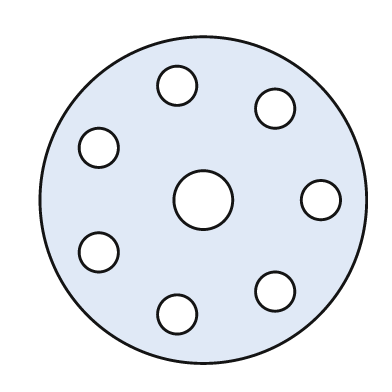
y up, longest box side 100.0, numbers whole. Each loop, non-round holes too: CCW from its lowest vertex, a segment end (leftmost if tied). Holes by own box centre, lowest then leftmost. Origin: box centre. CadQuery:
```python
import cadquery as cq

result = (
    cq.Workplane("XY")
    .moveTo(0.0, 0.0)
    .circle(50.0)
    .moveTo(-8.0, -35.0)
    .circle(6.0)
    .moveTo(22.0, -28.0)
    .circle(6.0)
    .moveTo(-32.0, -16.0)
    .circle(6.0)
    .moveTo(0.0, 0.0)
    .circle(9.0)
    .moveTo(36.0, 0.0)
    .circle(6.0)
    .moveTo(-32.0, 16.0)
    .circle(6.0)
    .moveTo(22.0, 28.0)
    .circle(6.0)
    .moveTo(-8.0, 35.0)
    .circle(6.0)
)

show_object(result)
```